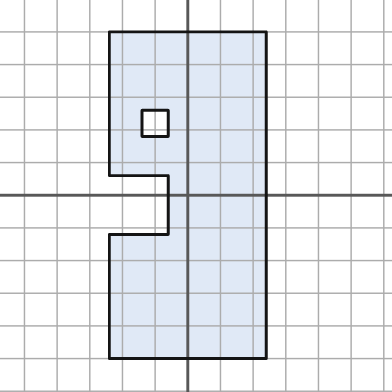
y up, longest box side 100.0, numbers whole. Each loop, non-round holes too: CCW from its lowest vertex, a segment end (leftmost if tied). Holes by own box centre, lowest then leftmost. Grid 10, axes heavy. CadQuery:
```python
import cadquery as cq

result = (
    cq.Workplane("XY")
    .moveTo(-24.0, -50.0)
    .lineTo(24.0, -50.0)
    .lineTo(24.0, 50.0)
    .lineTo(-24.0, 50.0)
    .lineTo(-24.0, 6.0)
    .lineTo(-6.0, 6.0)
    .lineTo(-6.0, -12.0)
    .lineTo(-24.0, -12.0)
    .close()
    .moveTo(-14.0, 18.0)
    .lineTo(-6.0, 18.0)
    .lineTo(-6.0, 26.0)
    .lineTo(-14.0, 26.0)
    .close()
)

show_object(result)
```